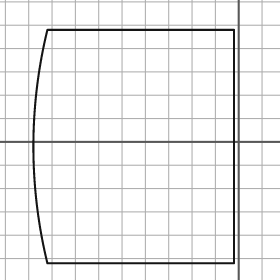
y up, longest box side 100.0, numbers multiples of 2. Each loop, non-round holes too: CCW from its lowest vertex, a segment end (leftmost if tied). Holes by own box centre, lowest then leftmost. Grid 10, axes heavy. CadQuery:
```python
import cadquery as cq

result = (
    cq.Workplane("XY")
    .moveTo(-82.0, -52.0)
    .lineTo(-2.0, -52.0)
    .lineTo(-2.0, 48.0)
    .lineTo(-82.0, 48.0)
    .threePointArc((-88.0, -2.0), (-82.0, -52.0))
    .close()
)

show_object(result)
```